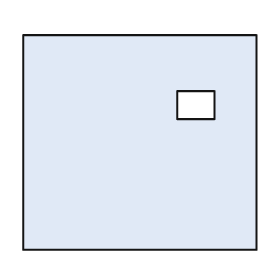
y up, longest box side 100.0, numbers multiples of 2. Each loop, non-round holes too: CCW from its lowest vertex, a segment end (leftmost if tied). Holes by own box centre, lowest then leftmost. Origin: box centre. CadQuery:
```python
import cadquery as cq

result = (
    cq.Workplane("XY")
    .moveTo(-50.0, -46.0)
    .lineTo(50.0, -46.0)
    .lineTo(50.0, 46.0)
    .lineTo(-50.0, 46.0)
    .close()
    .moveTo(16.0, 10.0)
    .lineTo(32.0, 10.0)
    .lineTo(32.0, 22.0)
    .lineTo(16.0, 22.0)
    .close()
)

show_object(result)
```